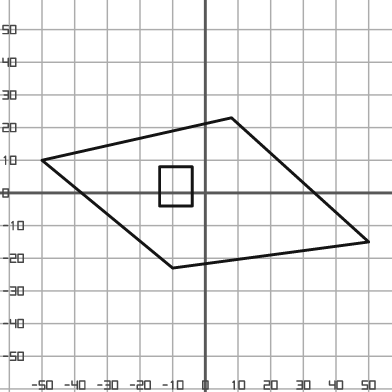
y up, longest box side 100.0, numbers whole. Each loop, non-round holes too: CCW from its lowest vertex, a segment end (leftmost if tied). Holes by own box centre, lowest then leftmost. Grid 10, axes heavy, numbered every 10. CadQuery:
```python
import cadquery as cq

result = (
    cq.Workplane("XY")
    .moveTo(-10.0, -23.0)
    .lineTo(50.0, -15.0)
    .lineTo(8.0, 23.0)
    .lineTo(-50.0, 10.0)
    .close()
    .moveTo(-14.0, -4.0)
    .lineTo(-4.0, -4.0)
    .lineTo(-4.0, 8.0)
    .lineTo(-14.0, 8.0)
    .close()
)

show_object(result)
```